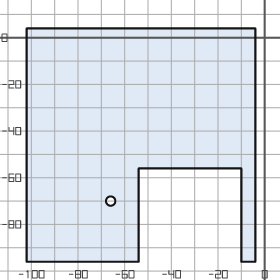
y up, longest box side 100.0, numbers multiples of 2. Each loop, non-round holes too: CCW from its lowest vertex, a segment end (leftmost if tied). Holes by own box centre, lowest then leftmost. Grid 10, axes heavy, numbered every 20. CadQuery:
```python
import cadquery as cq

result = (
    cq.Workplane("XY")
    .moveTo(-102.0, -96.0)
    .lineTo(-54.0, -96.0)
    .lineTo(-54.0, -56.0)
    .lineTo(-10.0, -56.0)
    .lineTo(-10.0, -96.0)
    .lineTo(-4.0, -96.0)
    .lineTo(-4.0, 4.0)
    .lineTo(-102.0, 4.0)
    .close()
    .moveTo(-66.0, -70.0)
    .circle(2.0)
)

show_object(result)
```